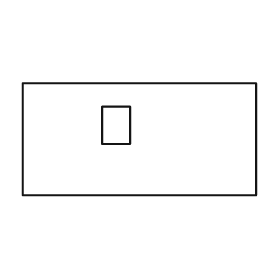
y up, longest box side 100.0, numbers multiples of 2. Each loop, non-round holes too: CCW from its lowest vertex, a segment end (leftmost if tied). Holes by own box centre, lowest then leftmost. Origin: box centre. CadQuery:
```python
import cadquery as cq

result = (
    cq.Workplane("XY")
    .moveTo(-50.0, -24.0)
    .lineTo(50.0, -24.0)
    .lineTo(50.0, 24.0)
    .lineTo(-50.0, 24.0)
    .close()
    .moveTo(-16.0, -2.0)
    .lineTo(-4.0, -2.0)
    .lineTo(-4.0, 14.0)
    .lineTo(-16.0, 14.0)
    .close()
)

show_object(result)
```